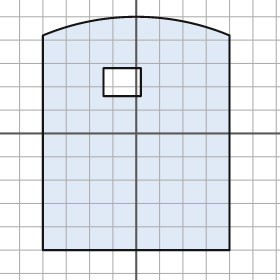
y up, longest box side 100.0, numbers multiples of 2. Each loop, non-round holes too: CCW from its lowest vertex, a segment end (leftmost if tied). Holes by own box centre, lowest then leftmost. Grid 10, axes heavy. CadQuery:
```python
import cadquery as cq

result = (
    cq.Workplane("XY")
    .moveTo(-40.0, -50.0)
    .lineTo(40.0, -50.0)
    .lineTo(40.0, 42.0)
    .threePointArc((0.0, 50.0), (-40.0, 42.0))
    .close()
    .moveTo(-14.0, 16.0)
    .lineTo(2.0, 16.0)
    .lineTo(2.0, 28.0)
    .lineTo(-14.0, 28.0)
    .close()
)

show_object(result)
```